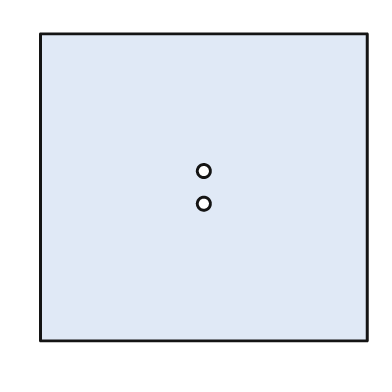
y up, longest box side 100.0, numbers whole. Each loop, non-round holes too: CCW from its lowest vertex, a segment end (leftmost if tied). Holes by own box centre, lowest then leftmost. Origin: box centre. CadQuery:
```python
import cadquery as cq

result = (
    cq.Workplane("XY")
    .moveTo(-50.0, -47.0)
    .lineTo(50.0, -47.0)
    .lineTo(50.0, 47.0)
    .lineTo(-50.0, 47.0)
    .close()
    .moveTo(0.0, -5.0)
    .circle(2.0)
    .moveTo(0.0, 5.0)
    .circle(2.0)
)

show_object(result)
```